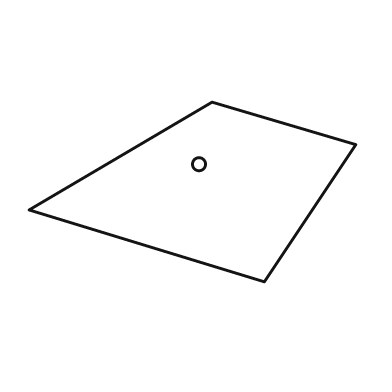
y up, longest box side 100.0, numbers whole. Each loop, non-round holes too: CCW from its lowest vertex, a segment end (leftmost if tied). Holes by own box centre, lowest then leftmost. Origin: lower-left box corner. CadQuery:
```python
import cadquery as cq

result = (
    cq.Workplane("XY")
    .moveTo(72.0, 0.0)
    .lineTo(100.0, 42.0)
    .lineTo(56.0, 55.0)
    .lineTo(0.0, 22.0)
    .close()
    .moveTo(52.0, 36.0)
    .circle(2.0)
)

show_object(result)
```